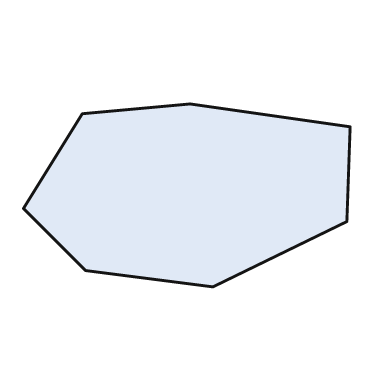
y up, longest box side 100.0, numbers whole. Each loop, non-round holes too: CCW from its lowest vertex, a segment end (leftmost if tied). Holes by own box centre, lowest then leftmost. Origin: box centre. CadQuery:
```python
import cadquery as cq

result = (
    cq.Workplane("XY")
    .moveTo(8.0, -28.0)
    .lineTo(49.0, -8.0)
    .lineTo(50.0, 21.0)
    .lineTo(1.0, 28.0)
    .lineTo(-32.0, 25.0)
    .lineTo(-50.0, -4.0)
    .lineTo(-31.0, -23.0)
    .close()
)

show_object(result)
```